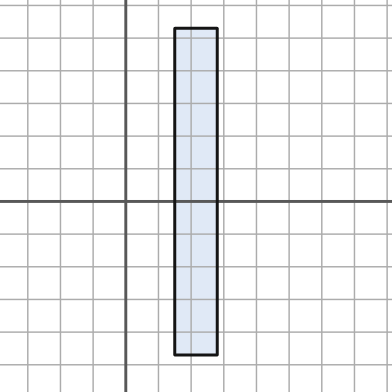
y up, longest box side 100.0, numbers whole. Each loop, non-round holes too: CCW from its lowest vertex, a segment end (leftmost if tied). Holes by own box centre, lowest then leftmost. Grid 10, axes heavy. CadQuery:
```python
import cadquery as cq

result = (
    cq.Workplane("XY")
    .moveTo(15.0, -47.0)
    .lineTo(28.0, -47.0)
    .lineTo(28.0, 53.0)
    .lineTo(15.0, 53.0)
    .close()
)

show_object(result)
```